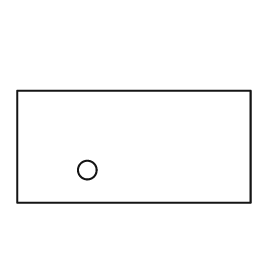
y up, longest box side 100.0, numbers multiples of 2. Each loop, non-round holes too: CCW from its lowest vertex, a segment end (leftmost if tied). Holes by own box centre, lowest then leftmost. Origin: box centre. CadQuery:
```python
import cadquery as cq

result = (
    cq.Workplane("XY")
    .moveTo(-50.0, -24.0)
    .lineTo(50.0, -24.0)
    .lineTo(50.0, 24.0)
    .lineTo(-50.0, 24.0)
    .close()
    .moveTo(-20.0, -10.0)
    .circle(4.0)
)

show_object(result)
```